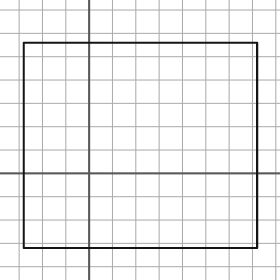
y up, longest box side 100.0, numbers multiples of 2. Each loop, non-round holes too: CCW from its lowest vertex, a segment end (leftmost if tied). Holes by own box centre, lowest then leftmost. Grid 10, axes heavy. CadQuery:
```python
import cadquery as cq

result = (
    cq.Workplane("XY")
    .moveTo(-28.0, -32.0)
    .lineTo(72.0, -32.0)
    .lineTo(72.0, 56.0)
    .lineTo(-28.0, 56.0)
    .close()
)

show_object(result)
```